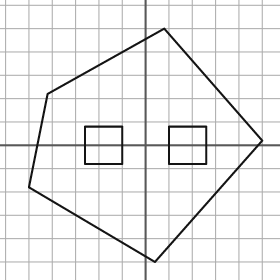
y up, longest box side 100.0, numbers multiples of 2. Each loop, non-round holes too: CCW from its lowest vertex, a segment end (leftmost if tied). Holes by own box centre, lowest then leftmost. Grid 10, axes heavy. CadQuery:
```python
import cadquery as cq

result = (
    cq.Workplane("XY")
    .moveTo(4.0, -50.0)
    .lineTo(50.0, 2.0)
    .lineTo(8.0, 50.0)
    .lineTo(-42.0, 22.0)
    .lineTo(-50.0, -18.0)
    .close()
    .moveTo(-26.0, -8.0)
    .lineTo(-10.0, -8.0)
    .lineTo(-10.0, 8.0)
    .lineTo(-26.0, 8.0)
    .close()
    .moveTo(10.0, -8.0)
    .lineTo(26.0, -8.0)
    .lineTo(26.0, 8.0)
    .lineTo(10.0, 8.0)
    .close()
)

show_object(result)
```